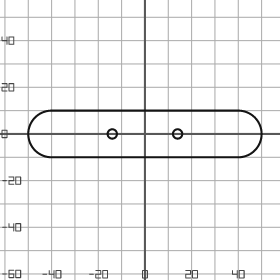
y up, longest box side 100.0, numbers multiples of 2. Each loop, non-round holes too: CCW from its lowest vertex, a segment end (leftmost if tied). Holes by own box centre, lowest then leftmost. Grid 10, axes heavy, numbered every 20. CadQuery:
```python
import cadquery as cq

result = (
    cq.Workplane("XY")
    .moveTo(-40.0, -10.0)
    .lineTo(40.0, -10.0)
    .threePointArc((50.0, 0.0), (40.0, 10.0))
    .lineTo(-40.0, 10.0)
    .threePointArc((-50.0, 0.0), (-40.0, -10.0))
    .close()
    .moveTo(-14.0, 0.0)
    .circle(2.0)
    .moveTo(14.0, 0.0)
    .circle(2.0)
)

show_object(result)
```